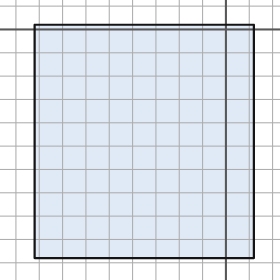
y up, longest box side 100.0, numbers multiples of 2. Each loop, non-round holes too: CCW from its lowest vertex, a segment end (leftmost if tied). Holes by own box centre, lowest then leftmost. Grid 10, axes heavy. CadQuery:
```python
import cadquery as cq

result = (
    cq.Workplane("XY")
    .moveTo(-82.0, -98.0)
    .lineTo(12.0, -98.0)
    .lineTo(12.0, 2.0)
    .lineTo(-82.0, 2.0)
    .close()
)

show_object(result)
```